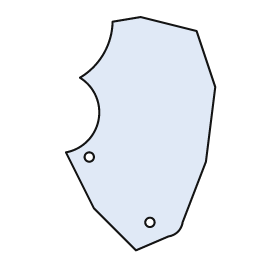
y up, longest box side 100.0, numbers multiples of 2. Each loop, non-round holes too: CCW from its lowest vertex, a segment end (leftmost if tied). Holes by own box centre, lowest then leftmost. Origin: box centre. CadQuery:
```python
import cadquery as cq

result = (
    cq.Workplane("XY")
    .moveTo(-2.0, -50.0)
    .lineTo(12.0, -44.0)
    .threePointArc((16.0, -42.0), (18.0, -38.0))
    .lineTo(28.0, -12.0)
    .lineTo(32.0, 20.0)
    .lineTo(24.0, 44.0)
    .lineTo(0.0, 50.0)
    .lineTo(-12.0, 48.0)
    .threePointArc((-16.0, 34.0), (-26.0, 24.0))
    .threePointArc((-18.0, 6.0), (-32.0, -8.0))
    .lineTo(-20.0, -32.0)
    .close()
    .moveTo(4.0, -38.0)
    .circle(2.0)
    .moveTo(-22.0, -10.0)
    .circle(2.0)
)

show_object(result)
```